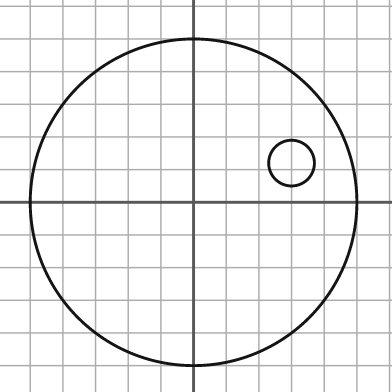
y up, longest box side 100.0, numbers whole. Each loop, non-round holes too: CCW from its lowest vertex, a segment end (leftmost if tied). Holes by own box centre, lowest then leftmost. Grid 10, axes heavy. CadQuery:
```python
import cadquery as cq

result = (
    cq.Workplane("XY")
    .moveTo(0.0, 0.0)
    .circle(50.0)
    .moveTo(30.0, 12.0)
    .circle(7.0)
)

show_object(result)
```